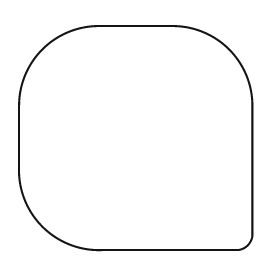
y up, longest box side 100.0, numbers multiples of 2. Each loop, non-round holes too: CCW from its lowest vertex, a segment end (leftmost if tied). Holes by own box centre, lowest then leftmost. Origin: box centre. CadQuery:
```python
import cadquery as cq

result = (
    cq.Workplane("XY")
    .moveTo(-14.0, -48.0)
    .lineTo(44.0, -48.0)
    .threePointArc((48.0, -46.0), (50.0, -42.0))
    .lineTo(50.0, 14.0)
    .threePointArc((40.0, 38.0), (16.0, 48.0))
    .lineTo(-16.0, 48.0)
    .threePointArc((-40.0, 38.0), (-50.0, 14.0))
    .lineTo(-50.0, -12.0)
    .threePointArc((-40.0, -38.0), (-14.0, -48.0))
    .close()
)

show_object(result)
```